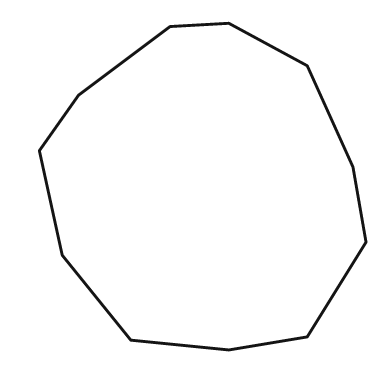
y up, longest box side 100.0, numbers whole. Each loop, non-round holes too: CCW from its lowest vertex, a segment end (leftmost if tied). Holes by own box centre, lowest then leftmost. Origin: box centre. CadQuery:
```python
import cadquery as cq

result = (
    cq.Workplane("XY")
    .moveTo(8.0, -50.0)
    .lineTo(32.0, -46.0)
    .lineTo(50.0, -17.0)
    .lineTo(46.0, 6.0)
    .lineTo(32.0, 37.0)
    .lineTo(8.0, 50.0)
    .lineTo(-10.0, 49.0)
    .lineTo(-38.0, 28.0)
    .lineTo(-50.0, 11.0)
    .lineTo(-43.0, -21.0)
    .lineTo(-22.0, -47.0)
    .close()
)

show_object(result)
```